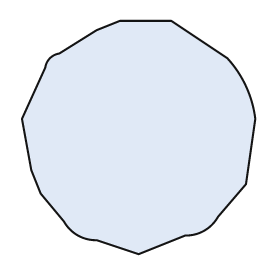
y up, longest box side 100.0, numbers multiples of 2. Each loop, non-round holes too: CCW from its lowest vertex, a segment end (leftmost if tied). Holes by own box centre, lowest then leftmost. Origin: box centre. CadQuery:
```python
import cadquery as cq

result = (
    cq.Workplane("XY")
    .moveTo(0.0, -50.0)
    .lineTo(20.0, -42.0)
    .threePointArc((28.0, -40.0), (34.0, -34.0))
    .lineTo(46.0, -20.0)
    .lineTo(50.0, 8.0)
    .threePointArc((46.0, 22.0), (38.0, 34.0))
    .lineTo(14.0, 50.0)
    .lineTo(-8.0, 50.0)
    .lineTo(-18.0, 46.0)
    .lineTo(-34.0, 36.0)
    .threePointArc((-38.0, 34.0), (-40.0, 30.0))
    .lineTo(-50.0, 8.0)
    .lineTo(-46.0, -14.0)
    .lineTo(-42.0, -24.0)
    .lineTo(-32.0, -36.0)
    .threePointArc((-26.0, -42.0), (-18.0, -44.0))
    .close()
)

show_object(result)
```